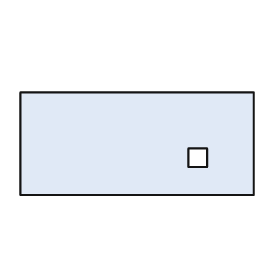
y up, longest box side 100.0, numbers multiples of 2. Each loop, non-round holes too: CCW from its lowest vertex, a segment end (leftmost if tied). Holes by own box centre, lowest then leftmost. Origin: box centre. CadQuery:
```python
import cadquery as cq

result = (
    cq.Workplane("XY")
    .moveTo(-50.0, -22.0)
    .lineTo(50.0, -22.0)
    .lineTo(50.0, 22.0)
    .lineTo(-50.0, 22.0)
    .close()
    .moveTo(22.0, -10.0)
    .lineTo(30.0, -10.0)
    .lineTo(30.0, -2.0)
    .lineTo(22.0, -2.0)
    .close()
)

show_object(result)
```